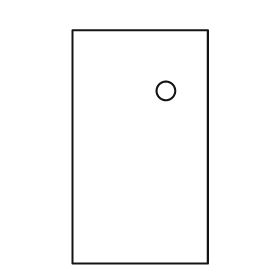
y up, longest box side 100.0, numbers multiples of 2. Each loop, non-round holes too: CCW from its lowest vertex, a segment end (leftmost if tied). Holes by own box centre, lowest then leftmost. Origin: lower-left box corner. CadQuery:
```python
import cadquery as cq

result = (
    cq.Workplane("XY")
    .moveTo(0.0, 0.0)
    .lineTo(58.0, 0.0)
    .lineTo(58.0, 100.0)
    .lineTo(0.0, 100.0)
    .close()
    .moveTo(40.0, 74.0)
    .circle(4.0)
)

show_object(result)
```